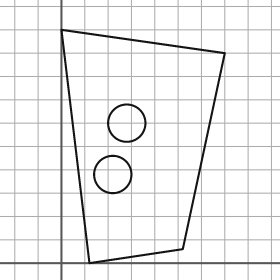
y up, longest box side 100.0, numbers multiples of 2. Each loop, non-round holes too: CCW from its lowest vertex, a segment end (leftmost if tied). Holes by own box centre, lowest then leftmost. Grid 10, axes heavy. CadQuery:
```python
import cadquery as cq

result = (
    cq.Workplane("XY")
    .moveTo(12.0, 0.0)
    .lineTo(52.0, 6.0)
    .lineTo(70.0, 90.0)
    .lineTo(0.0, 100.0)
    .close()
    .moveTo(22.0, 38.0)
    .circle(8.0)
    .moveTo(28.0, 60.0)
    .circle(8.0)
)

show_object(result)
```